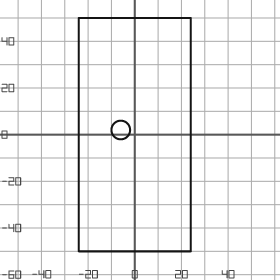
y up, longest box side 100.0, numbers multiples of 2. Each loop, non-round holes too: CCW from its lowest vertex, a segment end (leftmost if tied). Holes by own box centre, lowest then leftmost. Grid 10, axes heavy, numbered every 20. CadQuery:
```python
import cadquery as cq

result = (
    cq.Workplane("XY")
    .moveTo(-24.0, -50.0)
    .lineTo(24.0, -50.0)
    .lineTo(24.0, 50.0)
    .lineTo(-24.0, 50.0)
    .close()
    .moveTo(-6.0, 2.0)
    .circle(4.0)
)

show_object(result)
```